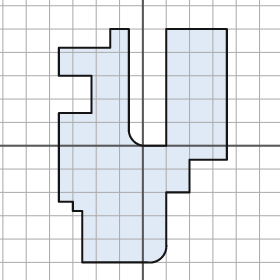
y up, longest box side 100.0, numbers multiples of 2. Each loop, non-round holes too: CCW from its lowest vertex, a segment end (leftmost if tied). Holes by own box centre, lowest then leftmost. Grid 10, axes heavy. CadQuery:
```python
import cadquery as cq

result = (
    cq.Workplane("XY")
    .moveTo(-26.0, -50.0)
    .lineTo(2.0, -50.0)
    .threePointArc((8.0, -48.0), (10.0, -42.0))
    .lineTo(10.0, -20.0)
    .lineTo(20.0, -20.0)
    .lineTo(20.0, -6.0)
    .lineTo(36.0, -6.0)
    .lineTo(36.0, 50.0)
    .lineTo(10.0, 50.0)
    .lineTo(10.0, 0.0)
    .lineTo(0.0, 0.0)
    .threePointArc((-4.0, 2.0), (-6.0, 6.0))
    .lineTo(-6.0, 50.0)
    .lineTo(-14.0, 50.0)
    .lineTo(-14.0, 42.0)
    .lineTo(-36.0, 42.0)
    .lineTo(-36.0, 30.0)
    .lineTo(-22.0, 30.0)
    .lineTo(-22.0, 14.0)
    .lineTo(-36.0, 14.0)
    .lineTo(-36.0, -24.0)
    .lineTo(-30.0, -24.0)
    .lineTo(-30.0, -28.0)
    .lineTo(-26.0, -28.0)
    .close()
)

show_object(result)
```